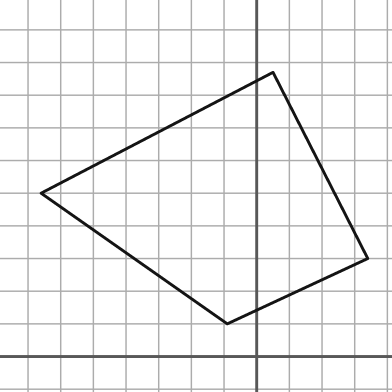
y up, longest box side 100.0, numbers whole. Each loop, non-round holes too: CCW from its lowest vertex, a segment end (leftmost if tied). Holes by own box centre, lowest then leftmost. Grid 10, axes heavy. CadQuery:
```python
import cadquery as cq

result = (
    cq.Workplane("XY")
    .moveTo(-9.0, 10.0)
    .lineTo(34.0, 30.0)
    .lineTo(5.0, 87.0)
    .lineTo(-66.0, 50.0)
    .close()
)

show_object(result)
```